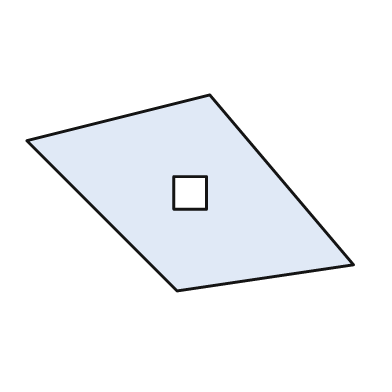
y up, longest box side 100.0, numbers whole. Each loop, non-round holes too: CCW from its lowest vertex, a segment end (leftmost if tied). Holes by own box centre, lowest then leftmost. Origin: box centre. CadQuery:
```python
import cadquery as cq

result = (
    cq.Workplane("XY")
    .moveTo(-4.0, -30.0)
    .lineTo(50.0, -22.0)
    .lineTo(6.0, 30.0)
    .lineTo(-50.0, 16.0)
    .close()
    .moveTo(-5.0, -5.0)
    .lineTo(5.0, -5.0)
    .lineTo(5.0, 5.0)
    .lineTo(-5.0, 5.0)
    .close()
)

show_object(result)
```